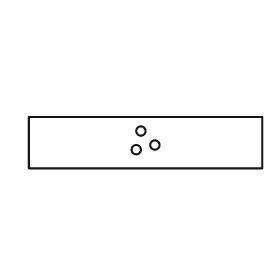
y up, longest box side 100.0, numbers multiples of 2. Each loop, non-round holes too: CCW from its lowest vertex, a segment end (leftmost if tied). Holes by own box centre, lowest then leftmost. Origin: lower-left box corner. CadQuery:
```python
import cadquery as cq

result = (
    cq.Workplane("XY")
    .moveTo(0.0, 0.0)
    .lineTo(100.0, 0.0)
    .lineTo(100.0, 22.0)
    .lineTo(0.0, 22.0)
    .close()
    .moveTo(46.0, 8.0)
    .circle(2.0)
    .moveTo(54.0, 10.0)
    .circle(2.0)
    .moveTo(48.0, 16.0)
    .circle(2.0)
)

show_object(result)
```